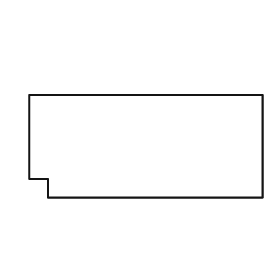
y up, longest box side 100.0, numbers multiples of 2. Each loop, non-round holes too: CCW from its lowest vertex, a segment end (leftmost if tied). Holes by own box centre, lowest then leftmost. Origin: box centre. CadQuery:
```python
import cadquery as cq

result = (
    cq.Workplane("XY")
    .moveTo(-42.0, -22.0)
    .lineTo(50.0, -22.0)
    .lineTo(50.0, 22.0)
    .lineTo(-50.0, 22.0)
    .lineTo(-50.0, -14.0)
    .lineTo(-42.0, -14.0)
    .close()
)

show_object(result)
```